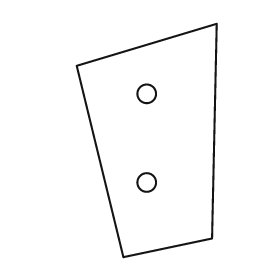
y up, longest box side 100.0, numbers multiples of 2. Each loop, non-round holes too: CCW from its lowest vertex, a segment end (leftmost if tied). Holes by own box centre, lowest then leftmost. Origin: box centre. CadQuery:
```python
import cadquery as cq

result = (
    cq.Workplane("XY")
    .moveTo(-10.0, -50.0)
    .lineTo(28.0, -42.0)
    .lineTo(30.0, 50.0)
    .lineTo(-30.0, 32.0)
    .close()
    .moveTo(0.0, -18.0)
    .circle(4.0)
    .moveTo(0.0, 20.0)
    .circle(4.0)
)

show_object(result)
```